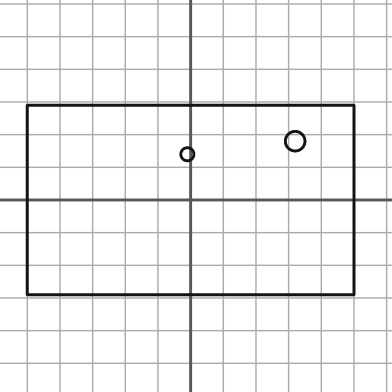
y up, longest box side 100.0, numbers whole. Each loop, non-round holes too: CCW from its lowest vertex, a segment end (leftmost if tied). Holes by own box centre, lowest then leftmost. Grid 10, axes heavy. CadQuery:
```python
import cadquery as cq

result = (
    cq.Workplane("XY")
    .moveTo(-50.0, -29.0)
    .lineTo(50.0, -29.0)
    .lineTo(50.0, 29.0)
    .lineTo(-50.0, 29.0)
    .close()
    .moveTo(-1.0, 14.0)
    .circle(2.0)
    .moveTo(32.0, 18.0)
    .circle(3.0)
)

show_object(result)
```